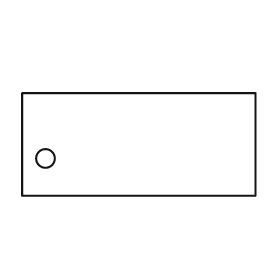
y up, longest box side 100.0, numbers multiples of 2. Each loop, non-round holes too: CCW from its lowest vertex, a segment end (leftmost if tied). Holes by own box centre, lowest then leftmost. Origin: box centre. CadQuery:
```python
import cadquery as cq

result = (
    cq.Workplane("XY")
    .moveTo(-50.0, -22.0)
    .lineTo(50.0, -22.0)
    .lineTo(50.0, 22.0)
    .lineTo(-50.0, 22.0)
    .close()
    .moveTo(-40.0, -6.0)
    .circle(4.0)
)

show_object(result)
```